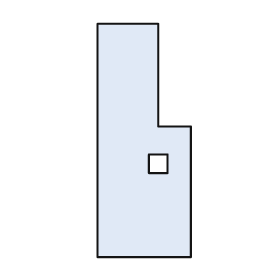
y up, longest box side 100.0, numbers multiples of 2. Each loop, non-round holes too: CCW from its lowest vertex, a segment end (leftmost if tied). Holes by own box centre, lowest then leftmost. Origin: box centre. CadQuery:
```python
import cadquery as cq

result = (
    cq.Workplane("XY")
    .moveTo(-20.0, -50.0)
    .lineTo(20.0, -50.0)
    .lineTo(20.0, 6.0)
    .lineTo(6.0, 6.0)
    .lineTo(6.0, 50.0)
    .lineTo(-20.0, 50.0)
    .close()
    .moveTo(2.0, -14.0)
    .lineTo(10.0, -14.0)
    .lineTo(10.0, -6.0)
    .lineTo(2.0, -6.0)
    .close()
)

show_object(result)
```